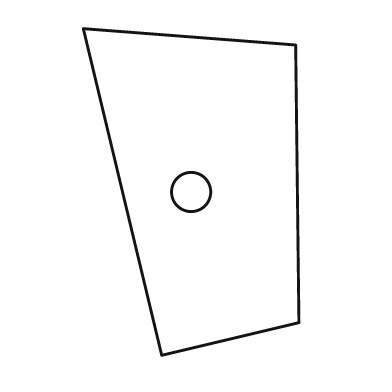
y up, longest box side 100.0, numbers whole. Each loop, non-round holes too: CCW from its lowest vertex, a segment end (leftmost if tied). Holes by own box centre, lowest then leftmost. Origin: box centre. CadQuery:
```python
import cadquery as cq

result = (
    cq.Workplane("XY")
    .moveTo(-9.0, -50.0)
    .lineTo(33.0, -40.0)
    .lineTo(32.0, 45.0)
    .lineTo(-33.0, 50.0)
    .close()
    .moveTo(0.0, 0.0)
    .circle(6.0)
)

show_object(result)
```